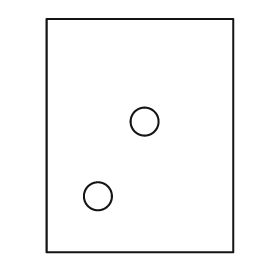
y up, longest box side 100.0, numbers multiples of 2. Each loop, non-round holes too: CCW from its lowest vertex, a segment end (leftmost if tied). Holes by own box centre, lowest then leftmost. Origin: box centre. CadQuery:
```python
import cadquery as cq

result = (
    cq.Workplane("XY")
    .moveTo(-40.0, -50.0)
    .lineTo(40.0, -50.0)
    .lineTo(40.0, 50.0)
    .lineTo(-40.0, 50.0)
    .close()
    .moveTo(-18.0, -26.0)
    .circle(6.0)
    .moveTo(2.0, 6.0)
    .circle(6.0)
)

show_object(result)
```